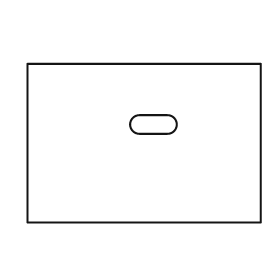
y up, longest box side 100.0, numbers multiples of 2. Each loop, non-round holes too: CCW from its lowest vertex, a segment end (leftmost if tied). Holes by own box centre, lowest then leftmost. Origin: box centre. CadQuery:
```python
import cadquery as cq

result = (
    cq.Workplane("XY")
    .moveTo(-50.0, -34.0)
    .lineTo(50.0, -34.0)
    .lineTo(50.0, 34.0)
    .lineTo(-50.0, 34.0)
    .close()
    .moveTo(-2.0, 4.0)
    .lineTo(10.0, 4.0)
    .threePointArc((14.0, 8.0), (10.0, 12.0))
    .lineTo(-2.0, 12.0)
    .threePointArc((-6.0, 8.0), (-2.0, 4.0))
    .close()
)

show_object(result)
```